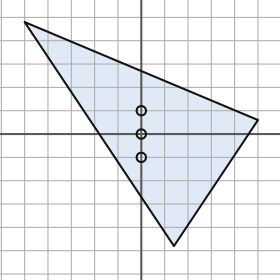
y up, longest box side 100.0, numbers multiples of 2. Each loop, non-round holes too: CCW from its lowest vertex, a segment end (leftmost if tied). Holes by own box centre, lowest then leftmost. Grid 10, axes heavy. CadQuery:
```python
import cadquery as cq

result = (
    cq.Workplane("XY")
    .moveTo(14.0, -48.0)
    .lineTo(50.0, 6.0)
    .lineTo(-50.0, 48.0)
    .close()
    .moveTo(0.0, -10.0)
    .circle(2.0)
    .moveTo(0.0, 0.0)
    .circle(2.0)
    .moveTo(0.0, 10.0)
    .circle(2.0)
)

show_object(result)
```